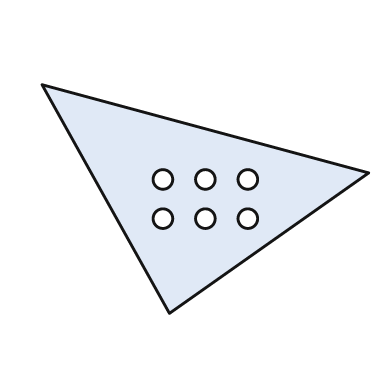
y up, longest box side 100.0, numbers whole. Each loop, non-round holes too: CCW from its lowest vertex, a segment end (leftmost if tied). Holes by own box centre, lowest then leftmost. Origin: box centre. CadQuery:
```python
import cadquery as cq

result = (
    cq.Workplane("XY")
    .moveTo(-11.0, -35.0)
    .lineTo(50.0, 8.0)
    .lineTo(-50.0, 35.0)
    .close()
    .moveTo(-13.0, -6.0)
    .circle(3.0)
    .moveTo(0.0, -6.0)
    .circle(3.0)
    .moveTo(13.0, -6.0)
    .circle(3.0)
    .moveTo(-13.0, 6.0)
    .circle(3.0)
    .moveTo(0.0, 6.0)
    .circle(3.0)
    .moveTo(13.0, 6.0)
    .circle(3.0)
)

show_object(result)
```